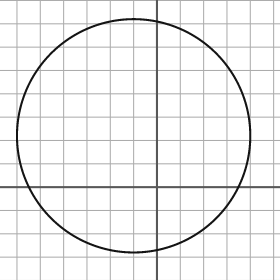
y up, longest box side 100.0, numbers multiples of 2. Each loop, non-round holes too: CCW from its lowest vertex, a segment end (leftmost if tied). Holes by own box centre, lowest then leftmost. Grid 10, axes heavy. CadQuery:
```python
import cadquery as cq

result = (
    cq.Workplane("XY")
    .moveTo(-10.0, 22.0)
    .circle(50.0)
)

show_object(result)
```